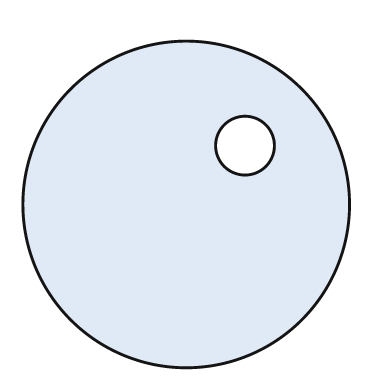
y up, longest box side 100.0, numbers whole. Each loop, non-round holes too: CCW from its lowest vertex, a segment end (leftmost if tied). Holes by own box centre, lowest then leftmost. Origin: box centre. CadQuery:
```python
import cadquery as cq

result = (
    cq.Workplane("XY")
    .moveTo(0.0, 0.0)
    .circle(50.0)
    .moveTo(18.0, 18.0)
    .circle(9.0)
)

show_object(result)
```